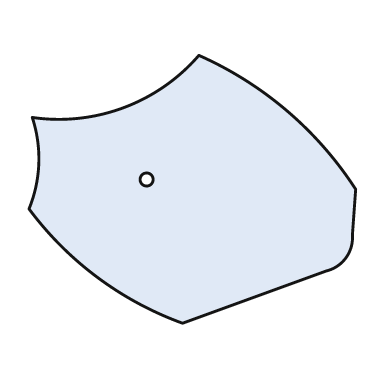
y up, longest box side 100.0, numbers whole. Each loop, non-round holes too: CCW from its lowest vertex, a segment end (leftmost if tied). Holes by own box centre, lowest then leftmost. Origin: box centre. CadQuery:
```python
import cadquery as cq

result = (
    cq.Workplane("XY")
    .moveTo(-3.0, -41.0)
    .lineTo(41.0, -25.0)
    .threePointArc((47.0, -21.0), (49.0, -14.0))
    .lineTo(50.0, 0.0)
    .threePointArc((29.0, 24.0), (2.0, 41.0))
    .threePointArc((-21.0, 25.0), (-49.0, 22.0))
    .threePointArc((-47.0, 8.0), (-50.0, -6.0))
    .threePointArc((-29.0, -27.0), (-3.0, -41.0))
    .close()
    .moveTo(-14.0, 3.0)
    .circle(2.0)
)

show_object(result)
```